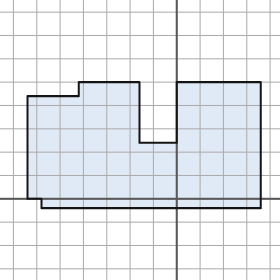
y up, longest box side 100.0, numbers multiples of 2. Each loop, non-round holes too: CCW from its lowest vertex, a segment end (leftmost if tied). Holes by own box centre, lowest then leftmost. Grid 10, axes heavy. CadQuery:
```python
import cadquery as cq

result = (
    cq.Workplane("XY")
    .moveTo(-58.0, -4.0)
    .lineTo(36.0, -4.0)
    .lineTo(36.0, 50.0)
    .lineTo(0.0, 50.0)
    .lineTo(0.0, 24.0)
    .lineTo(-16.0, 24.0)
    .lineTo(-16.0, 50.0)
    .lineTo(-42.0, 50.0)
    .lineTo(-42.0, 44.0)
    .lineTo(-64.0, 44.0)
    .lineTo(-64.0, 0.0)
    .lineTo(-58.0, 0.0)
    .close()
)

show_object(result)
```